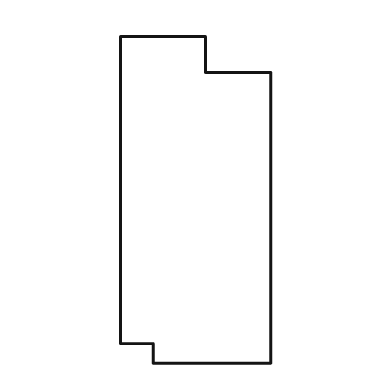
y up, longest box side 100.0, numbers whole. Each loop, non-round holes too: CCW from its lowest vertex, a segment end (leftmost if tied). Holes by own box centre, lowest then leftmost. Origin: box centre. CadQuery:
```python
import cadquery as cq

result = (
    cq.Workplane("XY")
    .moveTo(-13.0, -50.0)
    .lineTo(23.0, -50.0)
    .lineTo(23.0, 39.0)
    .lineTo(3.0, 39.0)
    .lineTo(3.0, 50.0)
    .lineTo(-23.0, 50.0)
    .lineTo(-23.0, -44.0)
    .lineTo(-13.0, -44.0)
    .close()
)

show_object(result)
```